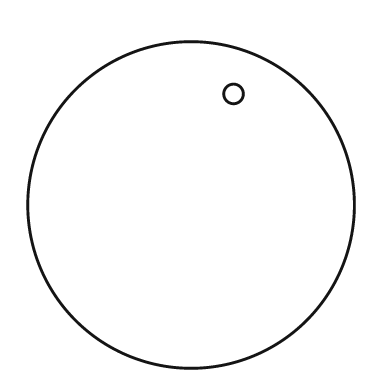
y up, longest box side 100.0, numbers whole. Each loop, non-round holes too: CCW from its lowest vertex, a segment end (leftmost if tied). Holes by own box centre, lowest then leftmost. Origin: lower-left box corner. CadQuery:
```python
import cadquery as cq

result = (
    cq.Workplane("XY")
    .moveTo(50.0, 50.0)
    .circle(50.0)
    .moveTo(63.0, 84.0)
    .circle(3.0)
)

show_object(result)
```